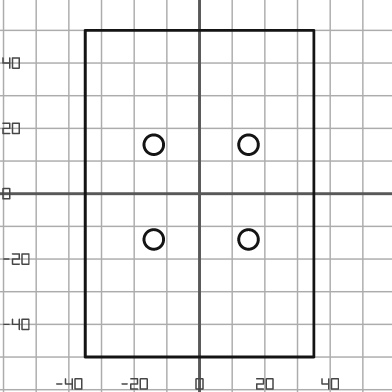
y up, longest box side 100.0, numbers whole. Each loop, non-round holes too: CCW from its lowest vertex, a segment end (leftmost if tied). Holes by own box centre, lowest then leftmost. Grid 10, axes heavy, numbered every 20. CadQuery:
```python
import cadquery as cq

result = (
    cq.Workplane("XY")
    .moveTo(-35.0, -50.0)
    .lineTo(35.0, -50.0)
    .lineTo(35.0, 50.0)
    .lineTo(-35.0, 50.0)
    .close()
    .moveTo(-14.0, -14.0)
    .circle(3.0)
    .moveTo(15.0, -14.0)
    .circle(3.0)
    .moveTo(-14.0, 15.0)
    .circle(3.0)
    .moveTo(15.0, 15.0)
    .circle(3.0)
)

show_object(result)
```